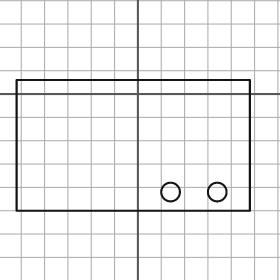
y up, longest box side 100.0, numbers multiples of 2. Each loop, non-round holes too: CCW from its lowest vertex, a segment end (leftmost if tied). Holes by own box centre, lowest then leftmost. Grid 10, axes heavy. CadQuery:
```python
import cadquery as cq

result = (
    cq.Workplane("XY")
    .moveTo(-52.0, -50.0)
    .lineTo(48.0, -50.0)
    .lineTo(48.0, 6.0)
    .lineTo(-52.0, 6.0)
    .close()
    .moveTo(14.0, -42.0)
    .circle(4.0)
    .moveTo(34.0, -42.0)
    .circle(4.0)
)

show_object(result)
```